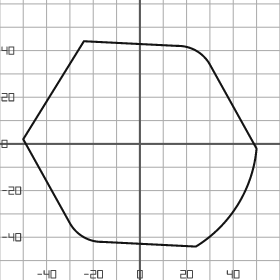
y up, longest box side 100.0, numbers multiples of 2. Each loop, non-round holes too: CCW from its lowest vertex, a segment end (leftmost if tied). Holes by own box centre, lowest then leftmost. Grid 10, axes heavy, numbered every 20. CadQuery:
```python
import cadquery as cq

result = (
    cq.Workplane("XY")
    .moveTo(24.0, -44.0)
    .threePointArc((42.0, -26.0), (50.0, -2.0))
    .lineTo(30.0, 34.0)
    .threePointArc((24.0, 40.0), (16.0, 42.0))
    .lineTo(-24.0, 44.0)
    .lineTo(-50.0, 2.0)
    .lineTo(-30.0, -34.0)
    .threePointArc((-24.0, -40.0), (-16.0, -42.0))
    .close()
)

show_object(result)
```